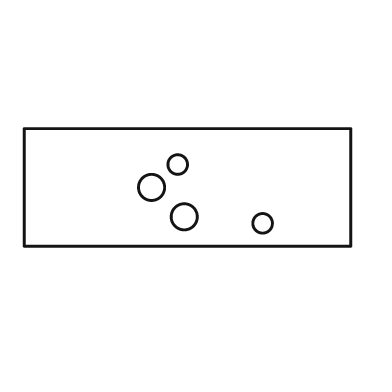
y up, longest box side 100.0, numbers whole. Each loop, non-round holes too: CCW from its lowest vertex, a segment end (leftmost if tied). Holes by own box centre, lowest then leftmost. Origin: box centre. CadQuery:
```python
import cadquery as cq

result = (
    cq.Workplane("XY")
    .moveTo(-50.0, -18.0)
    .lineTo(50.0, -18.0)
    .lineTo(50.0, 18.0)
    .lineTo(-50.0, 18.0)
    .close()
    .moveTo(23.0, -11.0)
    .circle(3.0)
    .moveTo(-1.0, -9.0)
    .circle(4.0)
    .moveTo(-11.0, 0.0)
    .circle(4.0)
    .moveTo(-3.0, 7.0)
    .circle(3.0)
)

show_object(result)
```